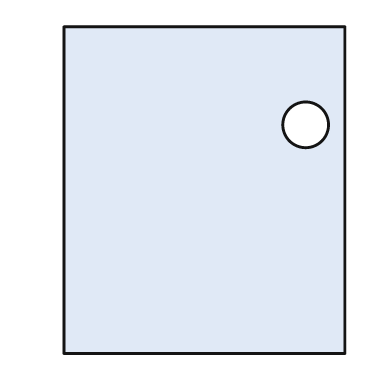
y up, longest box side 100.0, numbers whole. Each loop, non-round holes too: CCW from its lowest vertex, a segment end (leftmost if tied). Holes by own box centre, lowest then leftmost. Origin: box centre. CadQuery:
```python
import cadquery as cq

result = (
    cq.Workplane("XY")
    .moveTo(-43.0, -50.0)
    .lineTo(43.0, -50.0)
    .lineTo(43.0, 50.0)
    .lineTo(-43.0, 50.0)
    .close()
    .moveTo(31.0, 20.0)
    .circle(7.0)
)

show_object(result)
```